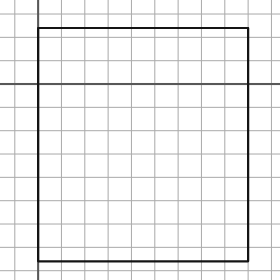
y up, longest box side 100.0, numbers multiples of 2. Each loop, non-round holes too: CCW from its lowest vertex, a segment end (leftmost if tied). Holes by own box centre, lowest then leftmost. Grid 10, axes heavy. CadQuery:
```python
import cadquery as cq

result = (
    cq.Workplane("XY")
    .moveTo(0.0, -76.0)
    .lineTo(90.0, -76.0)
    .lineTo(90.0, 24.0)
    .lineTo(0.0, 24.0)
    .close()
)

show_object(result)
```